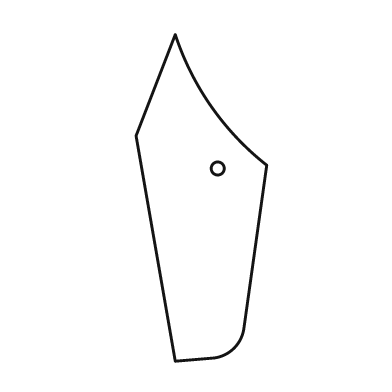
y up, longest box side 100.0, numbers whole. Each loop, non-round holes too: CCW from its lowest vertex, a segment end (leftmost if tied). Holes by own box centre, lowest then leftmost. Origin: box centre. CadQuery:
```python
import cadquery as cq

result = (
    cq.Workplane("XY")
    .moveTo(-8.0, -50.0)
    .lineTo(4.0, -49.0)
    .threePointArc((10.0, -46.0), (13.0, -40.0))
    .lineTo(20.0, 10.0)
    .threePointArc((3.0, 28.0), (-8.0, 50.0))
    .lineTo(-20.0, 19.0)
    .close()
    .moveTo(5.0, 9.0)
    .circle(2.0)
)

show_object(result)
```